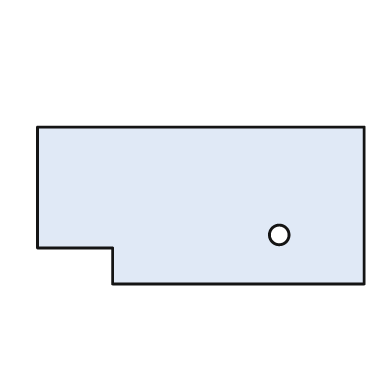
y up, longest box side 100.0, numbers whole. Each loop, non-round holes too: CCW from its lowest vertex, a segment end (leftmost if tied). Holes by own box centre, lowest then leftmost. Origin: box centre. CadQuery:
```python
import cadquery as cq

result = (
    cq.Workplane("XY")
    .moveTo(-27.0, -24.0)
    .lineTo(50.0, -24.0)
    .lineTo(50.0, 24.0)
    .lineTo(-50.0, 24.0)
    .lineTo(-50.0, -13.0)
    .lineTo(-27.0, -13.0)
    .close()
    .moveTo(24.0, -9.0)
    .circle(3.0)
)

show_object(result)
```